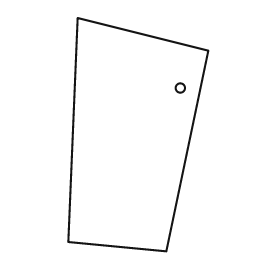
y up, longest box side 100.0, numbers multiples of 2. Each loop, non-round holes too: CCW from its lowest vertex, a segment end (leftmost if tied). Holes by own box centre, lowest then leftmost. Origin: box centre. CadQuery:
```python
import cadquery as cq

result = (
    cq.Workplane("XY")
    .moveTo(12.0, -50.0)
    .lineTo(30.0, 36.0)
    .lineTo(-26.0, 50.0)
    .lineTo(-30.0, -46.0)
    .close()
    .moveTo(18.0, 20.0)
    .circle(2.0)
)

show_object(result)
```